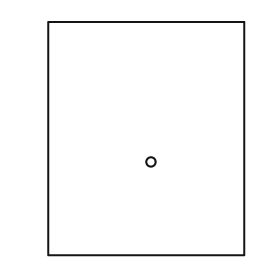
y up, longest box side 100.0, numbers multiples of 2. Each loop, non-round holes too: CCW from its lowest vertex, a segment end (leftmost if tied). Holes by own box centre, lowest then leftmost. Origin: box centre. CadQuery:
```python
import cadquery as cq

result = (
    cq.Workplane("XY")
    .moveTo(-42.0, -50.0)
    .lineTo(42.0, -50.0)
    .lineTo(42.0, 50.0)
    .lineTo(-42.0, 50.0)
    .close()
    .moveTo(2.0, -10.0)
    .circle(2.0)
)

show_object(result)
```